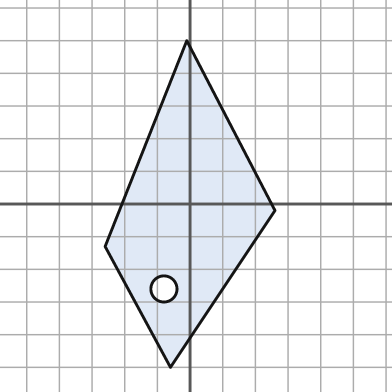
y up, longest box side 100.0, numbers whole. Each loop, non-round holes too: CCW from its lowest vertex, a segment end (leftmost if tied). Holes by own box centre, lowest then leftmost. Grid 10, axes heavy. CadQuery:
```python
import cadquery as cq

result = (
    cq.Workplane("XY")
    .moveTo(-6.0, -50.0)
    .lineTo(26.0, -2.0)
    .lineTo(-1.0, 50.0)
    .lineTo(-26.0, -13.0)
    .close()
    .moveTo(-8.0, -26.0)
    .circle(4.0)
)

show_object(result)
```